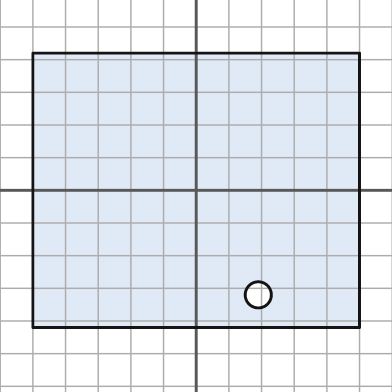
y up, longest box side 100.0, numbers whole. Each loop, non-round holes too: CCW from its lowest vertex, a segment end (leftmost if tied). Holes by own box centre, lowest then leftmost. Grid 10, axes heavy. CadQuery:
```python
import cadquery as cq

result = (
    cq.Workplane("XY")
    .moveTo(-50.0, -42.0)
    .lineTo(50.0, -42.0)
    .lineTo(50.0, 42.0)
    .lineTo(-50.0, 42.0)
    .close()
    .moveTo(19.0, -32.0)
    .circle(4.0)
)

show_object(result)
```